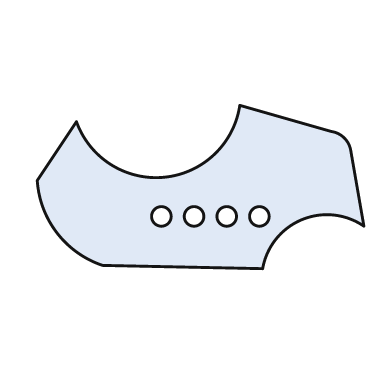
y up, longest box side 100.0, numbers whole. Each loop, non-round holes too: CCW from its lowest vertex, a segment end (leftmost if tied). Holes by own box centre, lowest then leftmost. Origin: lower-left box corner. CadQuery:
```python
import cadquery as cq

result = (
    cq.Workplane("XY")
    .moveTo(69.0, 0.0)
    .threePointArc((81.0, 15.0), (100.0, 13.0))
    .lineTo(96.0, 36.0)
    .threePointArc((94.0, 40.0), (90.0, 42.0))
    .lineTo(62.0, 50.0)
    .threePointArc((39.0, 28.0), (12.0, 45.0))
    .lineTo(0.0, 27.0)
    .threePointArc((6.0, 11.0), (20.0, 1.0))
    .close()
    .moveTo(38.0, 16.0)
    .circle(3.0)
    .moveTo(48.0, 16.0)
    .circle(3.0)
    .moveTo(58.0, 16.0)
    .circle(3.0)
    .moveTo(68.0, 16.0)
    .circle(3.0)
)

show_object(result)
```